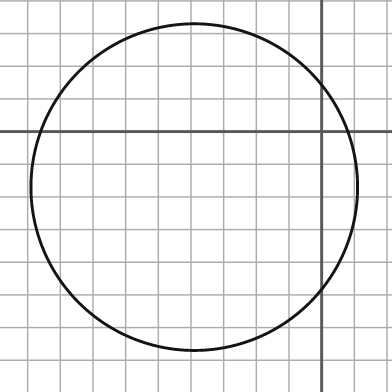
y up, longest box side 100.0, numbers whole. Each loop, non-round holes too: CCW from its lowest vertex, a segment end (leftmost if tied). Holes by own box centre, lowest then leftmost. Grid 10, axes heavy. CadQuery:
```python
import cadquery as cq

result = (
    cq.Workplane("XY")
    .moveTo(-39.0, -17.0)
    .circle(50.0)
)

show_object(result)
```